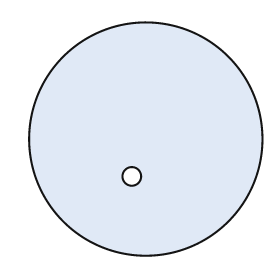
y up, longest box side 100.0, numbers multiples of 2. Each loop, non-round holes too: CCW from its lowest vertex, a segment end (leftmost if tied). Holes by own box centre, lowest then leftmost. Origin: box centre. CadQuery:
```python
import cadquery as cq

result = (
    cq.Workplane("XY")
    .moveTo(0.0, 0.0)
    .circle(50.0)
    .moveTo(-6.0, -16.0)
    .circle(4.0)
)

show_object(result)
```